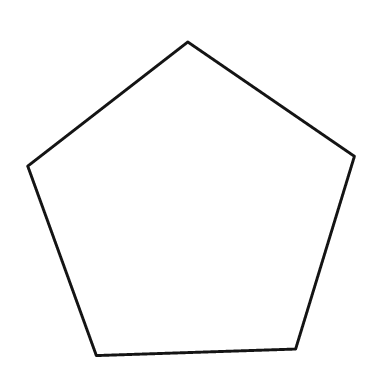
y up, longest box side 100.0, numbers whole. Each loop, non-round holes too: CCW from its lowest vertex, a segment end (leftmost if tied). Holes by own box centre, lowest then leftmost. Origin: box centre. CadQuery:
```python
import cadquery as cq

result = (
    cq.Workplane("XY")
    .moveTo(-29.0, -48.0)
    .lineTo(32.0, -46.0)
    .lineTo(50.0, 13.0)
    .lineTo(-1.0, 48.0)
    .lineTo(-50.0, 10.0)
    .close()
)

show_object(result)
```